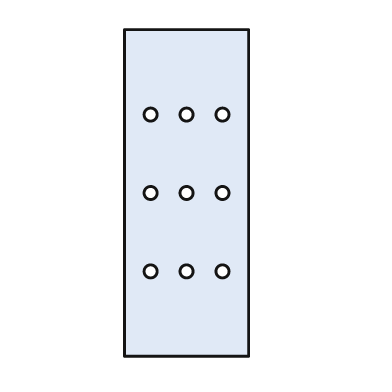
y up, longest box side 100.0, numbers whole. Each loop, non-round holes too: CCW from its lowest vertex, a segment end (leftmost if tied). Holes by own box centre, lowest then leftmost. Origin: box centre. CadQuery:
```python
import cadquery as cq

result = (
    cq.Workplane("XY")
    .moveTo(-19.0, -50.0)
    .lineTo(19.0, -50.0)
    .lineTo(19.0, 50.0)
    .lineTo(-19.0, 50.0)
    .close()
    .moveTo(-11.0, -24.0)
    .circle(2.0)
    .moveTo(0.0, -24.0)
    .circle(2.0)
    .moveTo(11.0, -24.0)
    .circle(2.0)
    .moveTo(-11.0, 0.0)
    .circle(2.0)
    .moveTo(0.0, 0.0)
    .circle(2.0)
    .moveTo(11.0, 0.0)
    .circle(2.0)
    .moveTo(-11.0, 24.0)
    .circle(2.0)
    .moveTo(0.0, 24.0)
    .circle(2.0)
    .moveTo(11.0, 24.0)
    .circle(2.0)
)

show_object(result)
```